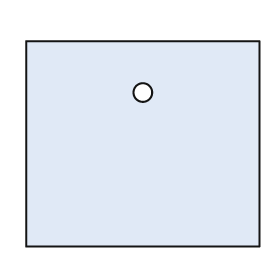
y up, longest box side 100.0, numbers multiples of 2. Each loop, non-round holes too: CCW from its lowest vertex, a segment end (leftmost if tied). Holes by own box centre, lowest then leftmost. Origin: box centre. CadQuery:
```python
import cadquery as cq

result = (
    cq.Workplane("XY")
    .moveTo(-50.0, -44.0)
    .lineTo(50.0, -44.0)
    .lineTo(50.0, 44.0)
    .lineTo(-50.0, 44.0)
    .close()
    .moveTo(0.0, 22.0)
    .circle(4.0)
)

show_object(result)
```